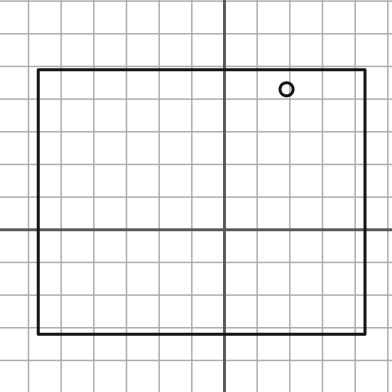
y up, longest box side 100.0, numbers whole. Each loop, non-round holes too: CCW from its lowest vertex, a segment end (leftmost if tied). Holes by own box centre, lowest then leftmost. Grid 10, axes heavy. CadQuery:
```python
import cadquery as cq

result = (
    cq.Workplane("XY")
    .moveTo(-57.0, -32.0)
    .lineTo(43.0, -32.0)
    .lineTo(43.0, 49.0)
    .lineTo(-57.0, 49.0)
    .close()
    .moveTo(19.0, 43.0)
    .circle(2.0)
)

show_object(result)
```